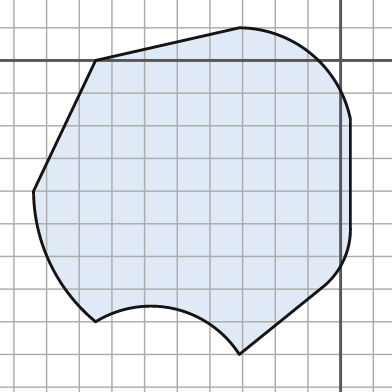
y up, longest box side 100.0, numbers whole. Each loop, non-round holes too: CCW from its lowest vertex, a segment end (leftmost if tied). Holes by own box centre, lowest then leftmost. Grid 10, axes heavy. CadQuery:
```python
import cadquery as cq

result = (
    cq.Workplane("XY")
    .moveTo(-31.0, -90.0)
    .lineTo(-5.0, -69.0)
    .threePointArc((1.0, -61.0), (3.0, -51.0))
    .lineTo(3.0, -18.0)
    .threePointArc((-9.0, 2.0), (-31.0, 10.0))
    .lineTo(-75.0, 0.0)
    .lineTo(-94.0, -40.0)
    .threePointArc((-89.0, -62.0), (-75.0, -80.0))
    .threePointArc((-51.0, -76.0), (-31.0, -90.0))
    .close()
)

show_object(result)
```